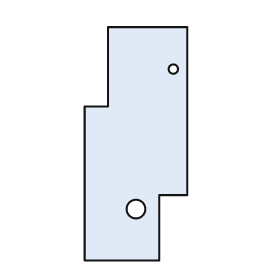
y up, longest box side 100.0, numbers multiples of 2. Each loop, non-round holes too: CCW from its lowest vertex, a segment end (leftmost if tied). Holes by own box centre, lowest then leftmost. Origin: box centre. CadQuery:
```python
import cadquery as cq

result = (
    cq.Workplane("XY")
    .moveTo(-22.0, -50.0)
    .lineTo(10.0, -50.0)
    .lineTo(10.0, -22.0)
    .lineTo(22.0, -22.0)
    .lineTo(22.0, 50.0)
    .lineTo(-12.0, 50.0)
    .lineTo(-12.0, 16.0)
    .lineTo(-22.0, 16.0)
    .close()
    .moveTo(0.0, -28.0)
    .circle(4.0)
    .moveTo(16.0, 32.0)
    .circle(2.0)
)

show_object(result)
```